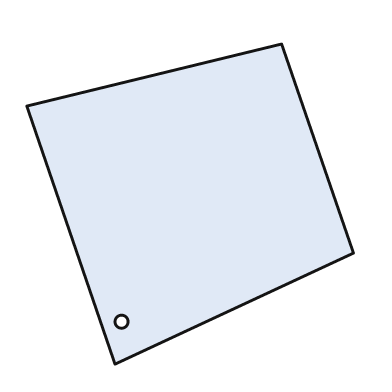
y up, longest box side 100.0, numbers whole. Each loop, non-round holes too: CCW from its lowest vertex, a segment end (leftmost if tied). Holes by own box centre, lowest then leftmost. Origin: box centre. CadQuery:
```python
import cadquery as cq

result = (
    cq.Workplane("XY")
    .moveTo(-23.0, -49.0)
    .lineTo(50.0, -15.0)
    .lineTo(28.0, 49.0)
    .lineTo(-50.0, 30.0)
    .close()
    .moveTo(-21.0, -36.0)
    .circle(2.0)
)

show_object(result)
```